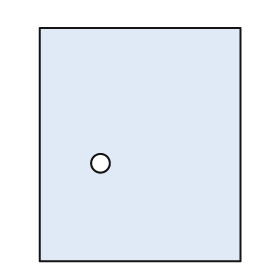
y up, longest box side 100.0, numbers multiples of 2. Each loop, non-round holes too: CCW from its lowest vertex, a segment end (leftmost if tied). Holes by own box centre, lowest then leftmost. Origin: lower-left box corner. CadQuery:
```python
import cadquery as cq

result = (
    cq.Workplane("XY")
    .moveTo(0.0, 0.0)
    .lineTo(86.0, 0.0)
    .lineTo(86.0, 100.0)
    .lineTo(0.0, 100.0)
    .close()
    .moveTo(26.0, 42.0)
    .circle(4.0)
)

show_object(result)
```